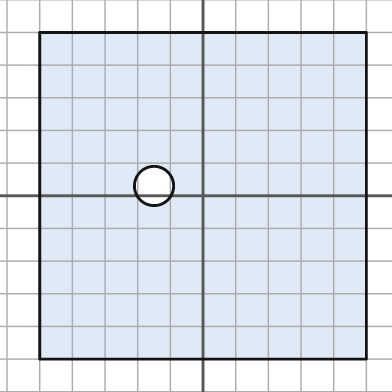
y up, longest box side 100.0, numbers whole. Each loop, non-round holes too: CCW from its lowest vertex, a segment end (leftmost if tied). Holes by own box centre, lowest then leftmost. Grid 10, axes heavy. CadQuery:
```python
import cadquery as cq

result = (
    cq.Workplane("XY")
    .moveTo(-50.0, -50.0)
    .lineTo(50.0, -50.0)
    .lineTo(50.0, 50.0)
    .lineTo(-50.0, 50.0)
    .close()
    .moveTo(-15.0, 3.0)
    .circle(6.0)
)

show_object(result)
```